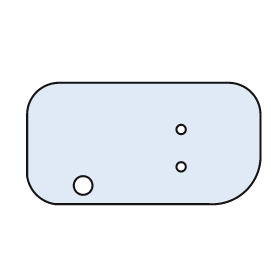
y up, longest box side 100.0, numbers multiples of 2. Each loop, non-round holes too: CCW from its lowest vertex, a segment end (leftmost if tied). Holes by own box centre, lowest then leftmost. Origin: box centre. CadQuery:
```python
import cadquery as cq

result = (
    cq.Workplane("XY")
    .moveTo(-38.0, -26.0)
    .lineTo(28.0, -26.0)
    .threePointArc((44.0, -20.0), (50.0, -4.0))
    .lineTo(50.0, 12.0)
    .threePointArc((46.0, 22.0), (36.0, 26.0))
    .lineTo(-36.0, 26.0)
    .threePointArc((-46.0, 22.0), (-50.0, 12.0))
    .lineTo(-50.0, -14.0)
    .threePointArc((-46.0, -22.0), (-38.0, -26.0))
    .close()
    .moveTo(-26.0, -18.0)
    .circle(4.0)
    .moveTo(16.0, -10.0)
    .circle(2.0)
    .moveTo(16.0, 6.0)
    .circle(2.0)
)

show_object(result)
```